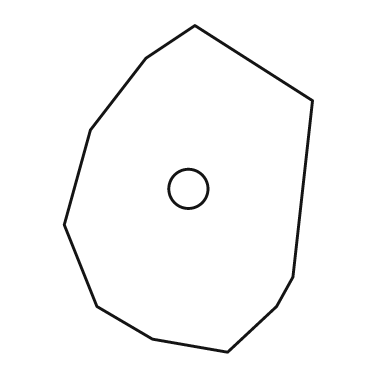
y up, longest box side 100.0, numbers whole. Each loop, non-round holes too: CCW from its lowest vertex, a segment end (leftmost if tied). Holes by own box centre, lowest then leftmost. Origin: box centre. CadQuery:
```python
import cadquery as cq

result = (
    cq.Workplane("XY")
    .moveTo(12.0, -50.0)
    .lineTo(27.0, -36.0)
    .lineTo(32.0, -27.0)
    .lineTo(38.0, 27.0)
    .lineTo(2.0, 50.0)
    .lineTo(-13.0, 40.0)
    .lineTo(-30.0, 18.0)
    .lineTo(-38.0, -11.0)
    .lineTo(-28.0, -36.0)
    .lineTo(-11.0, -46.0)
    .close()
    .moveTo(0.0, 0.0)
    .circle(6.0)
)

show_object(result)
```